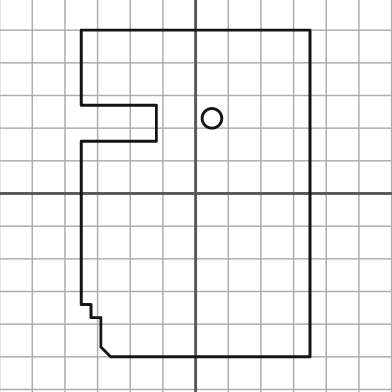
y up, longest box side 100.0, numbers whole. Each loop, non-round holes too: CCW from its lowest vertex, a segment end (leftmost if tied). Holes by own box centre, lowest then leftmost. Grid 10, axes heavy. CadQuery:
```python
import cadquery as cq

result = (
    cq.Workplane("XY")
    .moveTo(-26.0, -50.0)
    .lineTo(35.0, -50.0)
    .lineTo(35.0, 50.0)
    .lineTo(-35.0, 50.0)
    .lineTo(-35.0, 27.0)
    .lineTo(-12.0, 27.0)
    .lineTo(-12.0, 16.0)
    .lineTo(-35.0, 16.0)
    .lineTo(-35.0, -34.0)
    .lineTo(-32.0, -34.0)
    .lineTo(-32.0, -38.0)
    .lineTo(-29.0, -38.0)
    .lineTo(-29.0, -47.0)
    .close()
    .moveTo(5.0, 23.0)
    .circle(3.0)
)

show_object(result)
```